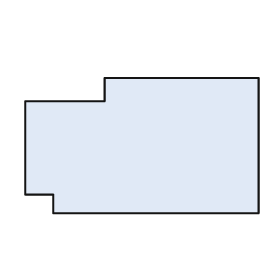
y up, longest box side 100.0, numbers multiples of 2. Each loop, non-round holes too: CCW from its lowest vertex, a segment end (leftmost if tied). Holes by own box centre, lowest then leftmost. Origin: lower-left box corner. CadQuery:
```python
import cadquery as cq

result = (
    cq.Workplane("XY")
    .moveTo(12.0, 0.0)
    .lineTo(100.0, 0.0)
    .lineTo(100.0, 58.0)
    .lineTo(34.0, 58.0)
    .lineTo(34.0, 48.0)
    .lineTo(0.0, 48.0)
    .lineTo(0.0, 8.0)
    .lineTo(12.0, 8.0)
    .close()
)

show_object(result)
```